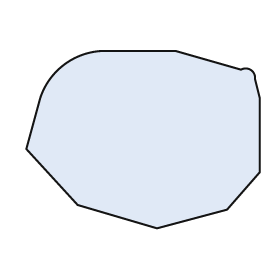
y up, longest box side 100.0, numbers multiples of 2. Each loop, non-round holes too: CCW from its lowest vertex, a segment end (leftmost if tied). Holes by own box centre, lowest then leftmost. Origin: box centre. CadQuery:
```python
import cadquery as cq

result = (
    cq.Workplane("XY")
    .moveTo(6.0, -38.0)
    .lineTo(36.0, -30.0)
    .lineTo(50.0, -14.0)
    .lineTo(50.0, 18.0)
    .lineTo(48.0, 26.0)
    .threePointArc((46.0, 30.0), (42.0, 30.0))
    .lineTo(14.0, 38.0)
    .lineTo(-18.0, 38.0)
    .threePointArc((-34.0, 32.0), (-44.0, 18.0))
    .lineTo(-50.0, -4.0)
    .lineTo(-28.0, -28.0)
    .close()
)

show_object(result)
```